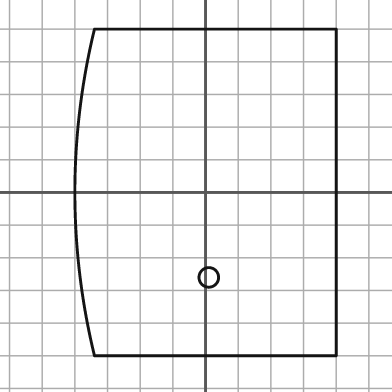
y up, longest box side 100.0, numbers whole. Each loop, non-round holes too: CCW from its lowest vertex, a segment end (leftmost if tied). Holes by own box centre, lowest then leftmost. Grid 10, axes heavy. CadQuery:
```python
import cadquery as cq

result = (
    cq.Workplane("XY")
    .moveTo(-34.0, -50.0)
    .lineTo(40.0, -50.0)
    .lineTo(40.0, 50.0)
    .lineTo(-34.0, 50.0)
    .threePointArc((-40.0, 0.0), (-34.0, -50.0))
    .close()
    .moveTo(1.0, -26.0)
    .circle(3.0)
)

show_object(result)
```